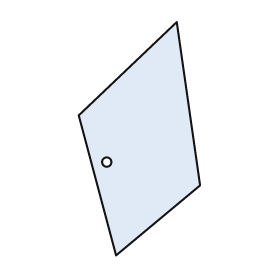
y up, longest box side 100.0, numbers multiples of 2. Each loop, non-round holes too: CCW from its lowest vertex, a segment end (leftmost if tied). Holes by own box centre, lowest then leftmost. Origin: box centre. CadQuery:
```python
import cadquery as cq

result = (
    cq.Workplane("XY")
    .moveTo(-10.0, -50.0)
    .lineTo(26.0, -20.0)
    .lineTo(16.0, 50.0)
    .lineTo(-26.0, 10.0)
    .close()
    .moveTo(-14.0, -10.0)
    .circle(2.0)
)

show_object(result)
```